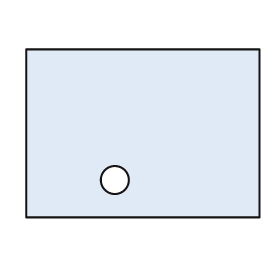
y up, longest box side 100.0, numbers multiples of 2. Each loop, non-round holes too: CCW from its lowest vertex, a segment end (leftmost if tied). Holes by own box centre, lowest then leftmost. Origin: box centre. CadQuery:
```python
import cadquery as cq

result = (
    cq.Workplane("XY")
    .moveTo(-50.0, -36.0)
    .lineTo(50.0, -36.0)
    .lineTo(50.0, 36.0)
    .lineTo(-50.0, 36.0)
    .close()
    .moveTo(-12.0, -20.0)
    .circle(6.0)
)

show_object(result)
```